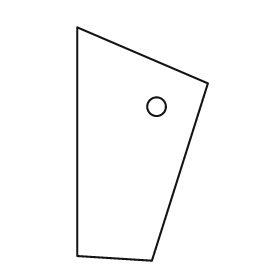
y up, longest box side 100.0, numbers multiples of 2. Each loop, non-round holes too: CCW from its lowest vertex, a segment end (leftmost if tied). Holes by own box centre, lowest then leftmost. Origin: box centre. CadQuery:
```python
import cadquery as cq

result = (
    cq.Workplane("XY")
    .moveTo(4.0, -50.0)
    .lineTo(28.0, 26.0)
    .lineTo(-28.0, 50.0)
    .lineTo(-28.0, -48.0)
    .close()
    .moveTo(6.0, 16.0)
    .circle(4.0)
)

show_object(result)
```